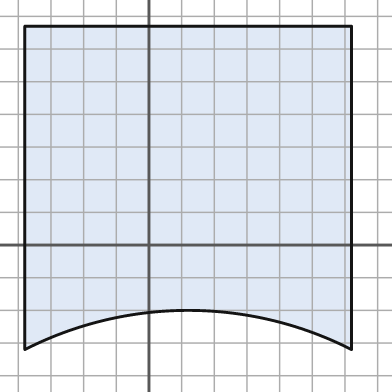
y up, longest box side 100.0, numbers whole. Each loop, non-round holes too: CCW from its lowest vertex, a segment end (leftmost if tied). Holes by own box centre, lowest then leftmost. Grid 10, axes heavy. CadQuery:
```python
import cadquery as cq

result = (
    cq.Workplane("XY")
    .moveTo(-38.0, -32.0)
    .threePointArc((12.0, -20.0), (62.0, -32.0))
    .lineTo(62.0, 67.0)
    .lineTo(-38.0, 67.0)
    .close()
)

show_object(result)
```